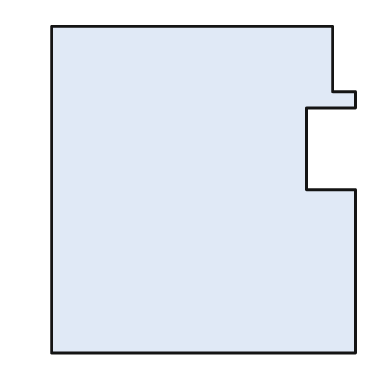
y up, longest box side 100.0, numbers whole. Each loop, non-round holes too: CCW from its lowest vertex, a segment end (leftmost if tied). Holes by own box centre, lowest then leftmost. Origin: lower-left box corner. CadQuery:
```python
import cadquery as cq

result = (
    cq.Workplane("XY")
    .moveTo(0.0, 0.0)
    .lineTo(93.0, 0.0)
    .lineTo(93.0, 50.0)
    .lineTo(78.0, 50.0)
    .lineTo(78.0, 75.0)
    .lineTo(93.0, 75.0)
    .lineTo(93.0, 80.0)
    .lineTo(86.0, 80.0)
    .lineTo(86.0, 100.0)
    .lineTo(0.0, 100.0)
    .close()
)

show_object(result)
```